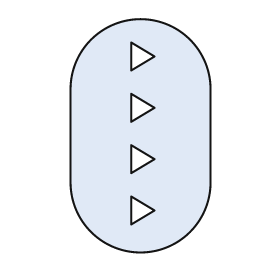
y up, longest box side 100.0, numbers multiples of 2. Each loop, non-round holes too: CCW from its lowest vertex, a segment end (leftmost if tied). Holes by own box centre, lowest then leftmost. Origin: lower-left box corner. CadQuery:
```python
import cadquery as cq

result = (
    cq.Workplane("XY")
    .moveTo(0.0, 30.0)
    .threePointArc((30.0, 0.0), (60.0, 30.0))
    .lineTo(60.0, 70.0)
    .threePointArc((30.0, 100.0), (0.0, 70.0))
    .close()
    .moveTo(26.0, 12.0)
    .lineTo(36.0, 18.0)
    .lineTo(26.0, 24.0)
    .close()
    .moveTo(26.0, 34.0)
    .lineTo(36.0, 40.0)
    .lineTo(26.0, 46.0)
    .close()
    .moveTo(26.0, 56.0)
    .lineTo(36.0, 62.0)
    .lineTo(26.0, 68.0)
    .close()
    .moveTo(26.0, 78.0)
    .lineTo(36.0, 84.0)
    .lineTo(26.0, 90.0)
    .close()
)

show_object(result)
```